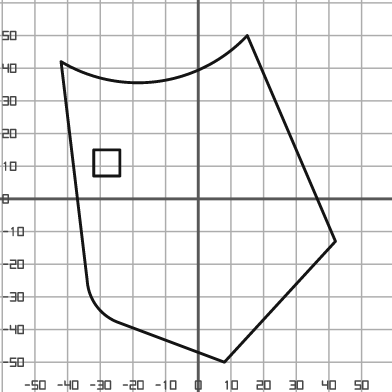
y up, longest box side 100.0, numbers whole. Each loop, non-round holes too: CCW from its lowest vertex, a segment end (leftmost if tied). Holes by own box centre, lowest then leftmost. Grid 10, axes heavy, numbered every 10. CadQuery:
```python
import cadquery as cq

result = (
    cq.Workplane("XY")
    .moveTo(8.0, -50.0)
    .lineTo(42.0, -13.0)
    .lineTo(15.0, 50.0)
    .threePointArc((-12.0, 36.0), (-42.0, 42.0))
    .lineTo(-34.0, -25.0)
    .threePointArc((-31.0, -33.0), (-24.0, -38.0))
    .close()
    .moveTo(-32.0, 7.0)
    .lineTo(-24.0, 7.0)
    .lineTo(-24.0, 15.0)
    .lineTo(-32.0, 15.0)
    .close()
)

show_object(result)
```